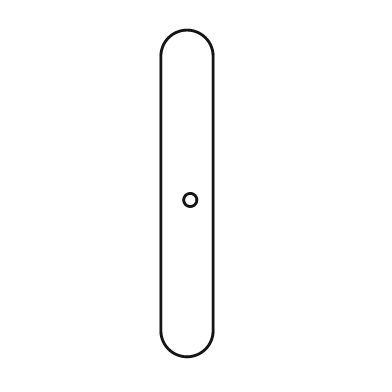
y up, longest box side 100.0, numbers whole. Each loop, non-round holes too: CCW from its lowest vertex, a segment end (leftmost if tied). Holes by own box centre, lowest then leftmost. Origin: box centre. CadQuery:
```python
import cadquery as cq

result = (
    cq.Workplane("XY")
    .moveTo(-8.0, -42.0)
    .threePointArc((0.0, -50.0), (8.0, -42.0))
    .lineTo(8.0, 42.0)
    .threePointArc((0.0, 50.0), (-8.0, 42.0))
    .close()
    .moveTo(1.0, -2.0)
    .circle(2.0)
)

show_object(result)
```